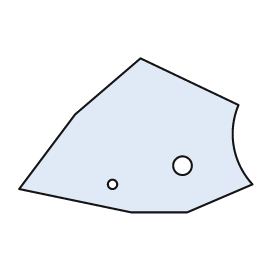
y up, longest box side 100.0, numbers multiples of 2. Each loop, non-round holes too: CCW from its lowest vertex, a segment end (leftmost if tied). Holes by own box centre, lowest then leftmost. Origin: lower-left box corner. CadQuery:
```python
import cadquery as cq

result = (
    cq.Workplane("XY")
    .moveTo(48.0, 0.0)
    .lineTo(72.0, 0.0)
    .lineTo(100.0, 12.0)
    .threePointArc((92.0, 28.0), (94.0, 46.0))
    .lineTo(52.0, 66.0)
    .lineTo(24.0, 42.0)
    .lineTo(0.0, 10.0)
    .close()
    .moveTo(40.0, 12.0)
    .circle(2.0)
    .moveTo(70.0, 20.0)
    .circle(4.0)
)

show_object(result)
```